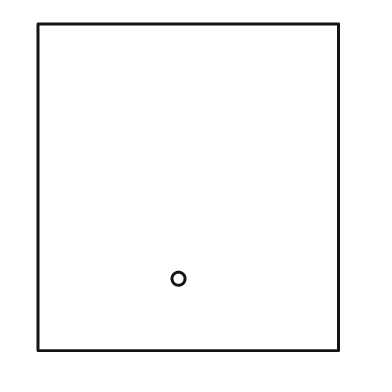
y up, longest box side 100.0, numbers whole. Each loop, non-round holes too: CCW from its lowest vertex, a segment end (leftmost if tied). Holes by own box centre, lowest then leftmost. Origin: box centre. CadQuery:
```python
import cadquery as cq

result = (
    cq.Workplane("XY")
    .moveTo(-46.0, -50.0)
    .lineTo(46.0, -50.0)
    .lineTo(46.0, 50.0)
    .lineTo(-46.0, 50.0)
    .close()
    .moveTo(-3.0, -28.0)
    .circle(2.0)
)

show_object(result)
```